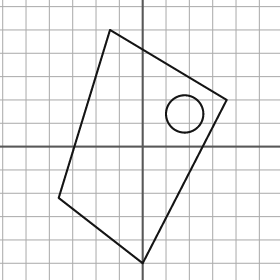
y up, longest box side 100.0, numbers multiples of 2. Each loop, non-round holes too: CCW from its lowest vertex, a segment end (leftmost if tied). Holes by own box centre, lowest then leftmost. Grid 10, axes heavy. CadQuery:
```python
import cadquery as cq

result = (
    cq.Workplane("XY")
    .moveTo(0.0, -50.0)
    .lineTo(36.0, 20.0)
    .lineTo(-14.0, 50.0)
    .lineTo(-36.0, -22.0)
    .close()
    .moveTo(18.0, 14.0)
    .circle(8.0)
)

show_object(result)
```